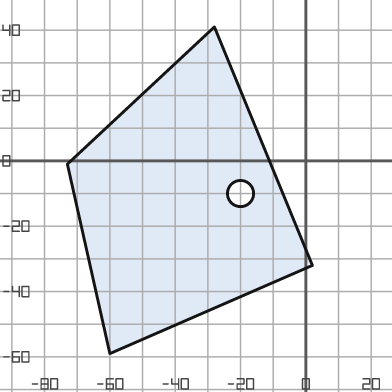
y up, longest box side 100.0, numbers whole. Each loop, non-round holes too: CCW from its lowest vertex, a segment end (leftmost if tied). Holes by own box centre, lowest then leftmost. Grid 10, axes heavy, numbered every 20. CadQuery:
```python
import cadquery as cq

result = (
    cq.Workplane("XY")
    .moveTo(-60.0, -59.0)
    .lineTo(2.0, -32.0)
    .lineTo(-28.0, 41.0)
    .lineTo(-73.0, -1.0)
    .close()
    .moveTo(-20.0, -10.0)
    .circle(4.0)
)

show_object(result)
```